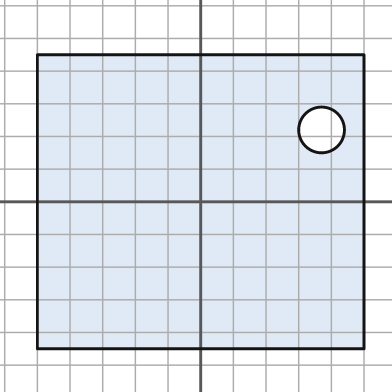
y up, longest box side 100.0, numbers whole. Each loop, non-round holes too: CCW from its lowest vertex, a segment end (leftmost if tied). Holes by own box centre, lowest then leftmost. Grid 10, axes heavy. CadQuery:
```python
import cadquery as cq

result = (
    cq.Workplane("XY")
    .moveTo(-50.0, -45.0)
    .lineTo(50.0, -45.0)
    .lineTo(50.0, 45.0)
    .lineTo(-50.0, 45.0)
    .close()
    .moveTo(37.0, 22.0)
    .circle(7.0)
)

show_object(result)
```